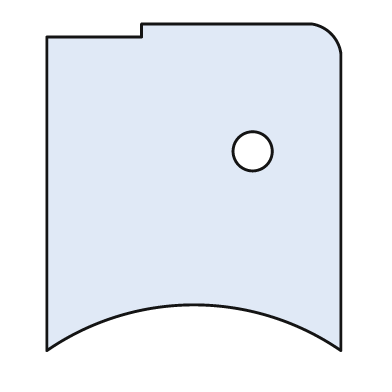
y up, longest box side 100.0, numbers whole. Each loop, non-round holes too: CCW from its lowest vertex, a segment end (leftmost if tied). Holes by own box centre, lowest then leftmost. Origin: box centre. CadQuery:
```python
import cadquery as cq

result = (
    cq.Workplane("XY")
    .moveTo(-45.0, -50.0)
    .threePointArc((0.0, -36.0), (45.0, -50.0))
    .lineTo(45.0, 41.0)
    .threePointArc((42.0, 47.0), (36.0, 50.0))
    .lineTo(-16.0, 50.0)
    .lineTo(-16.0, 46.0)
    .lineTo(-45.0, 46.0)
    .close()
    .moveTo(18.0, 11.0)
    .circle(6.0)
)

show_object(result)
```